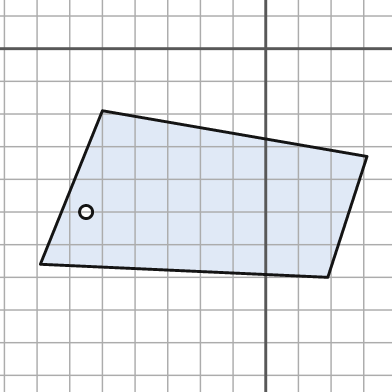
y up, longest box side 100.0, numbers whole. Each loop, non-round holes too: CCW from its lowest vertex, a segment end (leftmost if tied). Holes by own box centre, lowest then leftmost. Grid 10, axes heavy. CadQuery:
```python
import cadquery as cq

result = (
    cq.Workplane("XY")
    .moveTo(19.0, -70.0)
    .lineTo(31.0, -33.0)
    .lineTo(-50.0, -19.0)
    .lineTo(-69.0, -66.0)
    .close()
    .moveTo(-55.0, -50.0)
    .circle(2.0)
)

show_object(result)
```